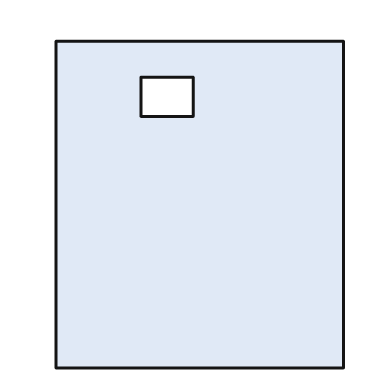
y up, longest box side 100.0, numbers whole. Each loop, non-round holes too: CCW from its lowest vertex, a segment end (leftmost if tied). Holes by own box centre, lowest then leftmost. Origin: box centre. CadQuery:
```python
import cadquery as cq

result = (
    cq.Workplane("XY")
    .moveTo(-44.0, -50.0)
    .lineTo(44.0, -50.0)
    .lineTo(44.0, 50.0)
    .lineTo(-44.0, 50.0)
    .close()
    .moveTo(-18.0, 27.0)
    .lineTo(-2.0, 27.0)
    .lineTo(-2.0, 39.0)
    .lineTo(-18.0, 39.0)
    .close()
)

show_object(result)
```